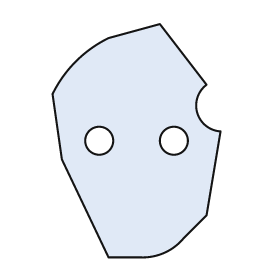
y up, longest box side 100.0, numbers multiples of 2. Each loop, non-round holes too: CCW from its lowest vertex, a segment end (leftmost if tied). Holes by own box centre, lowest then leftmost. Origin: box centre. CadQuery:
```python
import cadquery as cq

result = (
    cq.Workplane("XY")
    .moveTo(-12.0, -50.0)
    .lineTo(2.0, -50.0)
    .threePointArc((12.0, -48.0), (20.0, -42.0))
    .lineTo(30.0, -32.0)
    .lineTo(36.0, 4.0)
    .threePointArc((26.0, 12.0), (30.0, 24.0))
    .lineTo(10.0, 50.0)
    .lineTo(-12.0, 44.0)
    .threePointArc((-26.0, 34.0), (-36.0, 20.0))
    .lineTo(-32.0, -8.0)
    .close()
    .moveTo(-16.0, 0.0)
    .circle(6.0)
    .moveTo(16.0, 0.0)
    .circle(6.0)
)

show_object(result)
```